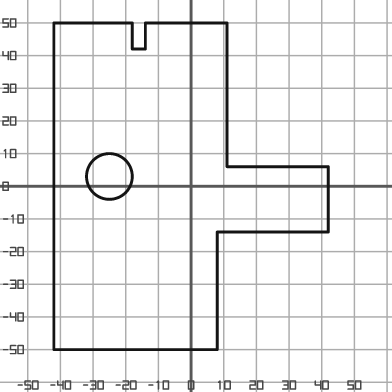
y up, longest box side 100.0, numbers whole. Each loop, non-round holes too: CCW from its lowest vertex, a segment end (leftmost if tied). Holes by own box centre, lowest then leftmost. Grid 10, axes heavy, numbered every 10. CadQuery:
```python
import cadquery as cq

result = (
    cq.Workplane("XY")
    .moveTo(-42.0, -50.0)
    .lineTo(8.0, -50.0)
    .lineTo(8.0, -14.0)
    .lineTo(42.0, -14.0)
    .lineTo(42.0, 6.0)
    .lineTo(11.0, 6.0)
    .lineTo(11.0, 50.0)
    .lineTo(-14.0, 50.0)
    .lineTo(-14.0, 42.0)
    .lineTo(-18.0, 42.0)
    .lineTo(-18.0, 50.0)
    .lineTo(-42.0, 50.0)
    .close()
    .moveTo(-25.0, 3.0)
    .circle(7.0)
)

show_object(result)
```